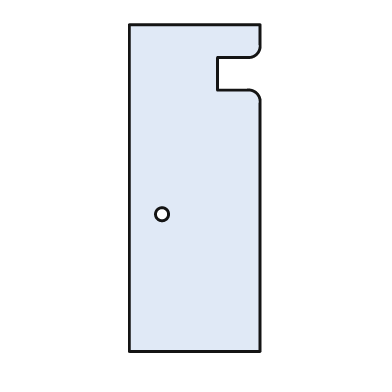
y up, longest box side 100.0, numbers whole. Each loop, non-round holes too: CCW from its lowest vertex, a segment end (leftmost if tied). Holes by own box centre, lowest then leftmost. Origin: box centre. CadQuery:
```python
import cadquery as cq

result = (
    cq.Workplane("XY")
    .moveTo(-20.0, -50.0)
    .lineTo(20.0, -50.0)
    .lineTo(20.0, 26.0)
    .threePointArc((19.0, 29.0), (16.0, 30.0))
    .lineTo(7.0, 30.0)
    .lineTo(7.0, 40.0)
    .lineTo(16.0, 40.0)
    .threePointArc((19.0, 41.0), (20.0, 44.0))
    .lineTo(20.0, 50.0)
    .lineTo(-20.0, 50.0)
    .close()
    .moveTo(-10.0, -8.0)
    .circle(2.0)
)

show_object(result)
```